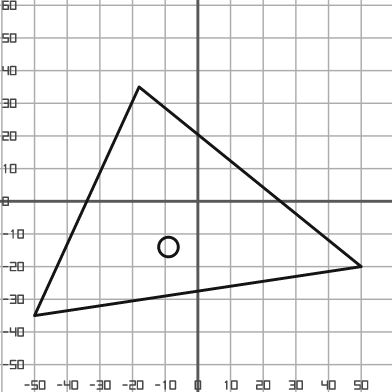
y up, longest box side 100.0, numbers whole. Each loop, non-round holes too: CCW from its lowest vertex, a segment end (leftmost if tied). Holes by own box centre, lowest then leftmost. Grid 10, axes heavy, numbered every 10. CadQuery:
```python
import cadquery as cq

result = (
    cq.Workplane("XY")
    .moveTo(-50.0, -35.0)
    .lineTo(50.0, -20.0)
    .lineTo(-18.0, 35.0)
    .close()
    .moveTo(-9.0, -14.0)
    .circle(3.0)
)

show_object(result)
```